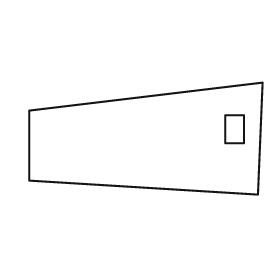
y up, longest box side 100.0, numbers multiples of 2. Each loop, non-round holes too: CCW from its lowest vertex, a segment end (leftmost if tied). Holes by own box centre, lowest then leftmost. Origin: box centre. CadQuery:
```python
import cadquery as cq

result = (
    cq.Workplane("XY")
    .moveTo(48.0, -24.0)
    .lineTo(50.0, 24.0)
    .lineTo(-50.0, 12.0)
    .lineTo(-50.0, -18.0)
    .close()
    .moveTo(34.0, -2.0)
    .lineTo(42.0, -2.0)
    .lineTo(42.0, 10.0)
    .lineTo(34.0, 10.0)
    .close()
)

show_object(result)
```